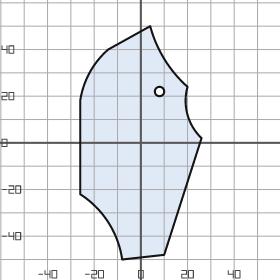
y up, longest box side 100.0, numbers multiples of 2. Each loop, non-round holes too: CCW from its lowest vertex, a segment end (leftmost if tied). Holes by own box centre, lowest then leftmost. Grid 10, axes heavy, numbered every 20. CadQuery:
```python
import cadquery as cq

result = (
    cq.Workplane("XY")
    .moveTo(-8.0, -50.0)
    .lineTo(10.0, -48.0)
    .lineTo(26.0, 2.0)
    .threePointArc((20.0, 12.0), (20.0, 24.0))
    .threePointArc((10.0, 36.0), (4.0, 50.0))
    .lineTo(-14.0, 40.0)
    .threePointArc((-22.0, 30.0), (-26.0, 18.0))
    .lineTo(-26.0, -22.0)
    .threePointArc((-14.0, -34.0), (-8.0, -50.0))
    .close()
    .moveTo(8.0, 22.0)
    .circle(2.0)
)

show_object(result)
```